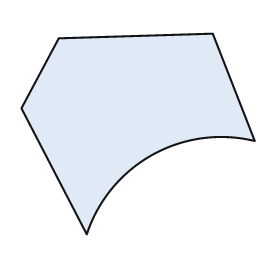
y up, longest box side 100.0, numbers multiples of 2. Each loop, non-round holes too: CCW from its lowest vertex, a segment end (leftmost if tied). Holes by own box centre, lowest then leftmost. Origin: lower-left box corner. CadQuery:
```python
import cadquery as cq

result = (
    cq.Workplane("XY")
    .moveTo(28.0, 0.0)
    .threePointArc((56.0, 34.0), (100.0, 40.0))
    .lineTo(82.0, 86.0)
    .lineTo(16.0, 84.0)
    .lineTo(0.0, 54.0)
    .close()
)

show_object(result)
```